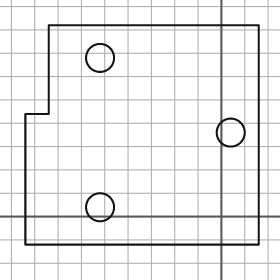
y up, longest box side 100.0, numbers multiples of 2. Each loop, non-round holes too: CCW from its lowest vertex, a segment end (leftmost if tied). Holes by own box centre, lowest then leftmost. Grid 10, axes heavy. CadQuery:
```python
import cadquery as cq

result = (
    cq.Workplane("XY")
    .moveTo(-84.0, -12.0)
    .lineTo(16.0, -12.0)
    .lineTo(16.0, 82.0)
    .lineTo(-74.0, 82.0)
    .lineTo(-74.0, 44.0)
    .lineTo(-84.0, 44.0)
    .close()
    .moveTo(-52.0, 4.0)
    .circle(6.0)
    .moveTo(4.0, 36.0)
    .circle(6.0)
    .moveTo(-52.0, 68.0)
    .circle(6.0)
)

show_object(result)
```